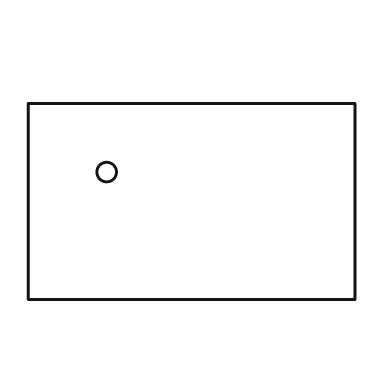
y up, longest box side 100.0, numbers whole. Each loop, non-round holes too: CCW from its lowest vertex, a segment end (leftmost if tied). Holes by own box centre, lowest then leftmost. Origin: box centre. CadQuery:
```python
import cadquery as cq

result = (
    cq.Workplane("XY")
    .moveTo(-50.0, -30.0)
    .lineTo(50.0, -30.0)
    .lineTo(50.0, 30.0)
    .lineTo(-50.0, 30.0)
    .close()
    .moveTo(-26.0, 9.0)
    .circle(3.0)
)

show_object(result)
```